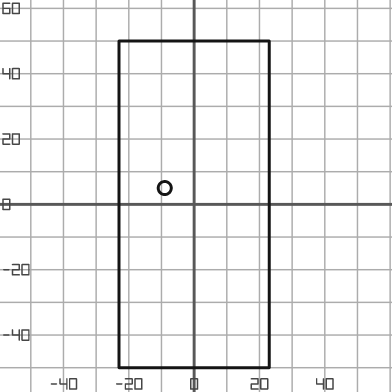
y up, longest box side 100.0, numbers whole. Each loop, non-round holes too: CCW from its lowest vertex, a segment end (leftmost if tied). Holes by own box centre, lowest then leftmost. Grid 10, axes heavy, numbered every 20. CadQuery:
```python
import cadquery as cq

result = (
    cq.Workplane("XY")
    .moveTo(-23.0, -50.0)
    .lineTo(23.0, -50.0)
    .lineTo(23.0, 50.0)
    .lineTo(-23.0, 50.0)
    .close()
    .moveTo(-9.0, 5.0)
    .circle(2.0)
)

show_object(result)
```